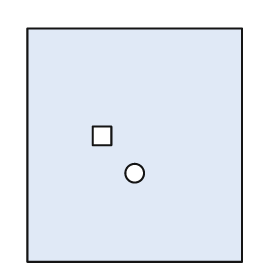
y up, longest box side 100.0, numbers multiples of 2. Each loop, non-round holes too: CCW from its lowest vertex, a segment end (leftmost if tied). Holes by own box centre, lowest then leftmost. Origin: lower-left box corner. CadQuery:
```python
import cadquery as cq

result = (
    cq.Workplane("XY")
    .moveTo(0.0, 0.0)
    .lineTo(92.0, 0.0)
    .lineTo(92.0, 100.0)
    .lineTo(0.0, 100.0)
    .close()
    .moveTo(46.0, 38.0)
    .circle(4.0)
    .moveTo(28.0, 50.0)
    .lineTo(36.0, 50.0)
    .lineTo(36.0, 58.0)
    .lineTo(28.0, 58.0)
    .close()
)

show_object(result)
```